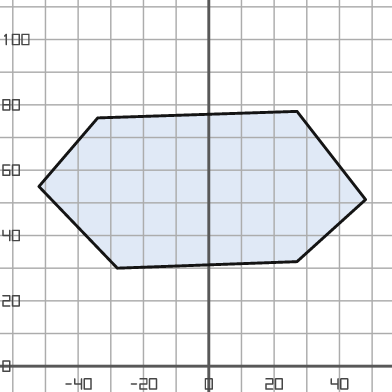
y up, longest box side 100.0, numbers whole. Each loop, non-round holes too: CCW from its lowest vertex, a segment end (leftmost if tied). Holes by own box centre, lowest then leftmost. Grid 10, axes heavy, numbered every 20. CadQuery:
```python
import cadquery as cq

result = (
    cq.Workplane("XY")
    .moveTo(-28.0, 30.0)
    .lineTo(27.0, 32.0)
    .lineTo(48.0, 51.0)
    .lineTo(27.0, 78.0)
    .lineTo(-34.0, 76.0)
    .lineTo(-52.0, 55.0)
    .close()
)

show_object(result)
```